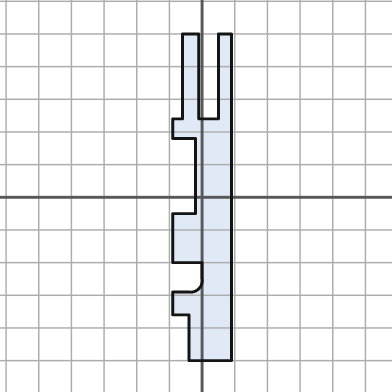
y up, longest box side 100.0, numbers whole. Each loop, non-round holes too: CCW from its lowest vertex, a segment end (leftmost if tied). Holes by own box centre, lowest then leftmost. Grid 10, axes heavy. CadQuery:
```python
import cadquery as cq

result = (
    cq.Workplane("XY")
    .moveTo(-4.0, -50.0)
    .lineTo(9.0, -50.0)
    .lineTo(9.0, 50.0)
    .lineTo(5.0, 50.0)
    .lineTo(5.0, 24.0)
    .lineTo(-1.0, 24.0)
    .lineTo(-1.0, 50.0)
    .lineTo(-6.0, 50.0)
    .lineTo(-6.0, 24.0)
    .lineTo(-9.0, 24.0)
    .lineTo(-9.0, 18.0)
    .lineTo(-2.0, 18.0)
    .lineTo(-2.0, -5.0)
    .lineTo(-9.0, -5.0)
    .lineTo(-9.0, -20.0)
    .lineTo(0.0, -20.0)
    .lineTo(0.0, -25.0)
    .threePointArc((-1.0, -28.0), (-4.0, -29.0))
    .lineTo(-9.0, -29.0)
    .lineTo(-9.0, -36.0)
    .lineTo(-4.0, -36.0)
    .close()
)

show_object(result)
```